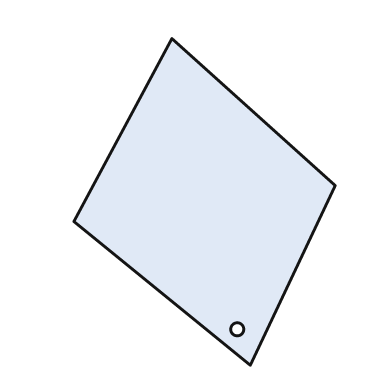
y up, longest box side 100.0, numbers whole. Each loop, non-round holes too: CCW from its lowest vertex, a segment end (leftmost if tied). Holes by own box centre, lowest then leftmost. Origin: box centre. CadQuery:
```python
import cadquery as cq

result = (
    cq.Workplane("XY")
    .moveTo(14.0, -50.0)
    .lineTo(40.0, 5.0)
    .lineTo(-10.0, 50.0)
    .lineTo(-40.0, -6.0)
    .close()
    .moveTo(10.0, -39.0)
    .circle(2.0)
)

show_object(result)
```